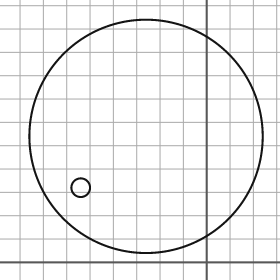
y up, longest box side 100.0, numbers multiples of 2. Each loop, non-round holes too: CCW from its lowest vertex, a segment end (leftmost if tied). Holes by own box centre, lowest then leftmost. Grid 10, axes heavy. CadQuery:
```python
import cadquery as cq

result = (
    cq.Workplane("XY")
    .moveTo(-26.0, 54.0)
    .circle(50.0)
    .moveTo(-54.0, 32.0)
    .circle(4.0)
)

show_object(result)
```